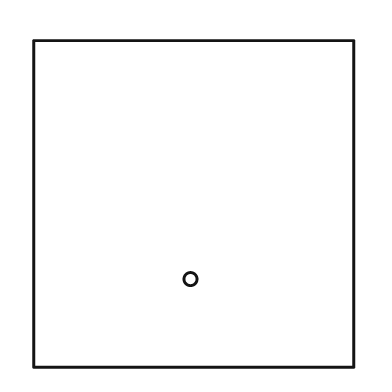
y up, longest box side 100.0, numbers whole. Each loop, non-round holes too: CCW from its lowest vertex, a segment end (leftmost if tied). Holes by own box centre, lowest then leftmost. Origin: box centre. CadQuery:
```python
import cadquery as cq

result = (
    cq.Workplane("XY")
    .moveTo(-49.0, -50.0)
    .lineTo(49.0, -50.0)
    .lineTo(49.0, 50.0)
    .lineTo(-49.0, 50.0)
    .close()
    .moveTo(-1.0, -23.0)
    .circle(2.0)
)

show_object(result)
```